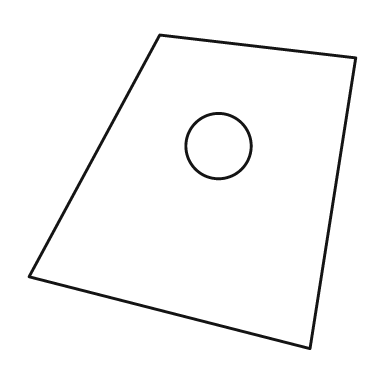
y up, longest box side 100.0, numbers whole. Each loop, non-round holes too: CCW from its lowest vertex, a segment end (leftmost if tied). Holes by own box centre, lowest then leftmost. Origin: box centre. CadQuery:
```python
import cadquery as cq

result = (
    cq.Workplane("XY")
    .moveTo(36.0, -48.0)
    .lineTo(50.0, 41.0)
    .lineTo(-10.0, 48.0)
    .lineTo(-50.0, -26.0)
    .close()
    .moveTo(8.0, 14.0)
    .circle(10.0)
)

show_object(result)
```